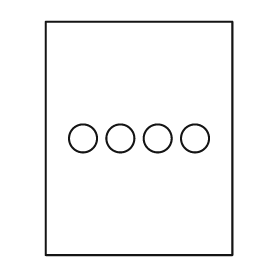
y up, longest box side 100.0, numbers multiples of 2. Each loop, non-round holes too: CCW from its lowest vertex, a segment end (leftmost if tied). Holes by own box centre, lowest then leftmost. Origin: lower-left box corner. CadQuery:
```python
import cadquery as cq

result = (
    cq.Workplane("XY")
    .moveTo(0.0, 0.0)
    .lineTo(80.0, 0.0)
    .lineTo(80.0, 100.0)
    .lineTo(0.0, 100.0)
    .close()
    .moveTo(16.0, 50.0)
    .circle(6.0)
    .moveTo(32.0, 50.0)
    .circle(6.0)
    .moveTo(48.0, 50.0)
    .circle(6.0)
    .moveTo(64.0, 50.0)
    .circle(6.0)
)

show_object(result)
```